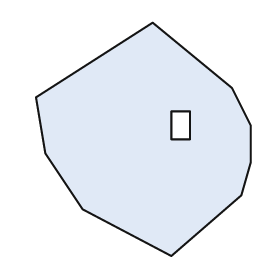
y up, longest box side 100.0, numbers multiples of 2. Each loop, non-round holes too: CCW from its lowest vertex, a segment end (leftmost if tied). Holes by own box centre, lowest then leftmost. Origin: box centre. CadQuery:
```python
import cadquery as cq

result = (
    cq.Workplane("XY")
    .moveTo(12.0, -50.0)
    .lineTo(42.0, -24.0)
    .lineTo(46.0, -10.0)
    .lineTo(46.0, 6.0)
    .lineTo(38.0, 22.0)
    .lineTo(4.0, 50.0)
    .lineTo(-46.0, 18.0)
    .lineTo(-42.0, -6.0)
    .lineTo(-26.0, -30.0)
    .close()
    .moveTo(12.0, 0.0)
    .lineTo(20.0, 0.0)
    .lineTo(20.0, 12.0)
    .lineTo(12.0, 12.0)
    .close()
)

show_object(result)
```